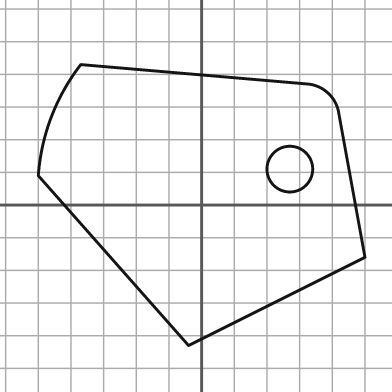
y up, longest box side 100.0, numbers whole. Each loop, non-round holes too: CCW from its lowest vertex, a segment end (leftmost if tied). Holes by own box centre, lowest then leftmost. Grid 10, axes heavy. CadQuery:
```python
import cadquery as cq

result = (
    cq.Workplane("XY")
    .moveTo(-4.0, -43.0)
    .lineTo(50.0, -16.0)
    .lineTo(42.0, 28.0)
    .threePointArc((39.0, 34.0), (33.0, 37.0))
    .lineTo(-37.0, 43.0)
    .threePointArc((-46.0, 27.0), (-50.0, 9.0))
    .close()
    .moveTo(27.0, 11.0)
    .circle(7.0)
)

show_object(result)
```